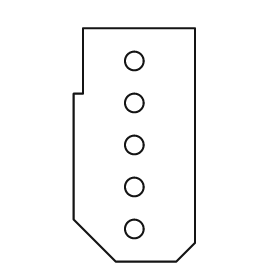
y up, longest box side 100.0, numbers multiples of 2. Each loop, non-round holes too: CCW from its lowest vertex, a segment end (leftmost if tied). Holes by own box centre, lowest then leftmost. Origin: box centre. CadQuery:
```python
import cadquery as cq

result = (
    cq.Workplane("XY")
    .moveTo(-8.0, -50.0)
    .lineTo(18.0, -50.0)
    .lineTo(26.0, -42.0)
    .lineTo(26.0, 50.0)
    .lineTo(-22.0, 50.0)
    .lineTo(-22.0, 22.0)
    .lineTo(-26.0, 22.0)
    .lineTo(-26.0, -32.0)
    .close()
    .moveTo(0.0, -36.0)
    .circle(4.0)
    .moveTo(0.0, -18.0)
    .circle(4.0)
    .moveTo(0.0, 0.0)
    .circle(4.0)
    .moveTo(0.0, 18.0)
    .circle(4.0)
    .moveTo(0.0, 36.0)
    .circle(4.0)
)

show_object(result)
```